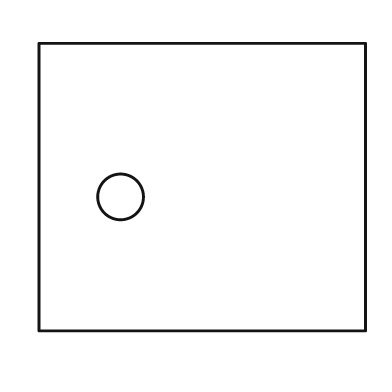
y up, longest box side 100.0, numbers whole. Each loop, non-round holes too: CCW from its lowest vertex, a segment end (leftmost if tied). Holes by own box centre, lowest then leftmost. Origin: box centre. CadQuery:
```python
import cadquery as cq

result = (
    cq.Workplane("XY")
    .moveTo(-50.0, -44.0)
    .lineTo(50.0, -44.0)
    .lineTo(50.0, 44.0)
    .lineTo(-50.0, 44.0)
    .close()
    .moveTo(-25.0, -3.0)
    .circle(7.0)
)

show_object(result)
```